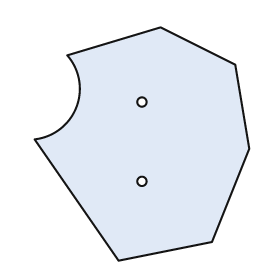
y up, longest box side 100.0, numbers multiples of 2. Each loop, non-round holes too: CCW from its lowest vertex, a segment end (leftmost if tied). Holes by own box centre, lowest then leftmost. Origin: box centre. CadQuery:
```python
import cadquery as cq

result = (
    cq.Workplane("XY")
    .moveTo(-10.0, -50.0)
    .lineTo(30.0, -42.0)
    .lineTo(46.0, -2.0)
    .lineTo(40.0, 34.0)
    .lineTo(8.0, 50.0)
    .lineTo(-32.0, 38.0)
    .threePointArc((-28.0, 16.0), (-46.0, 2.0))
    .close()
    .moveTo(0.0, -16.0)
    .circle(2.0)
    .moveTo(0.0, 18.0)
    .circle(2.0)
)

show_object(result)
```